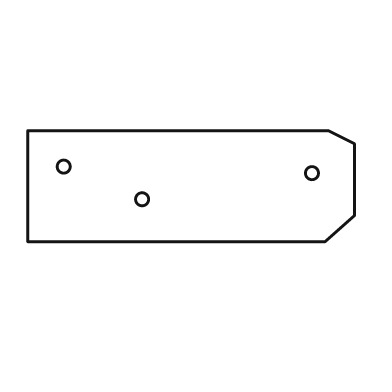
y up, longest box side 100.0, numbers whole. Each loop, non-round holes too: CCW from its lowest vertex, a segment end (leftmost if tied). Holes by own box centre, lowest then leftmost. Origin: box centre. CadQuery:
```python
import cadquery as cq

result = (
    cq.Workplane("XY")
    .moveTo(-50.0, -17.0)
    .lineTo(41.0, -17.0)
    .lineTo(50.0, -9.0)
    .lineTo(50.0, 13.0)
    .lineTo(42.0, 17.0)
    .lineTo(-50.0, 17.0)
    .close()
    .moveTo(-15.0, -4.0)
    .circle(2.0)
    .moveTo(37.0, 4.0)
    .circle(2.0)
    .moveTo(-39.0, 6.0)
    .circle(2.0)
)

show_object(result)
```